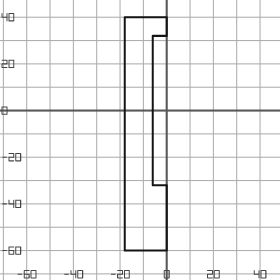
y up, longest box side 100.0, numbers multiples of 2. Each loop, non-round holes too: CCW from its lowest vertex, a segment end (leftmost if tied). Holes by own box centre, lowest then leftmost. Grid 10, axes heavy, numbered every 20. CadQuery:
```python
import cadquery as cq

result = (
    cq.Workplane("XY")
    .moveTo(-18.0, -60.0)
    .lineTo(0.0, -60.0)
    .lineTo(0.0, -32.0)
    .lineTo(-6.0, -32.0)
    .lineTo(-6.0, 32.0)
    .lineTo(0.0, 32.0)
    .lineTo(0.0, 40.0)
    .lineTo(-18.0, 40.0)
    .close()
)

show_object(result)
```